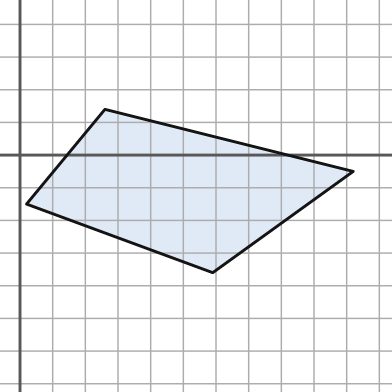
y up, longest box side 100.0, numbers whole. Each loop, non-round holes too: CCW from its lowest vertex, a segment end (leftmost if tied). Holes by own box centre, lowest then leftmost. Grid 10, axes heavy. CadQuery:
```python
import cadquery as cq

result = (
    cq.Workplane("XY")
    .moveTo(59.0, -36.0)
    .lineTo(102.0, -5.0)
    .lineTo(26.0, 14.0)
    .lineTo(2.0, -15.0)
    .close()
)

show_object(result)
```